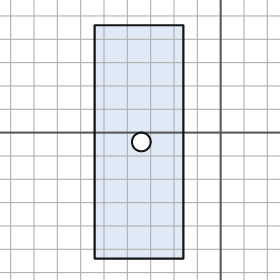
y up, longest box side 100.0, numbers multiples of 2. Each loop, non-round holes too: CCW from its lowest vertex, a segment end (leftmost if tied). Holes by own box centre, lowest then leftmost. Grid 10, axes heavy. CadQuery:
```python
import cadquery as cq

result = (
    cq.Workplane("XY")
    .moveTo(-54.0, -54.0)
    .lineTo(-16.0, -54.0)
    .lineTo(-16.0, 46.0)
    .lineTo(-54.0, 46.0)
    .close()
    .moveTo(-34.0, -4.0)
    .circle(4.0)
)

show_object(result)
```